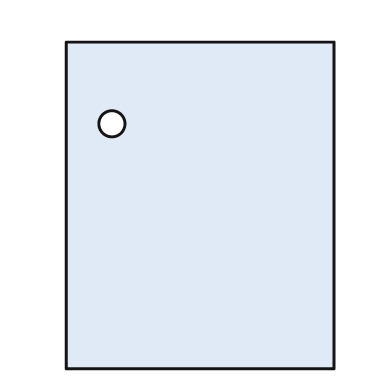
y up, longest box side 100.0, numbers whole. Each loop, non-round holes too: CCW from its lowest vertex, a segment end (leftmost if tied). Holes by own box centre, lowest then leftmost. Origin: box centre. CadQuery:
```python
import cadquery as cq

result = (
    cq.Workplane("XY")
    .moveTo(-41.0, -50.0)
    .lineTo(41.0, -50.0)
    .lineTo(41.0, 50.0)
    .lineTo(-41.0, 50.0)
    .close()
    .moveTo(-27.0, 25.0)
    .circle(4.0)
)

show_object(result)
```